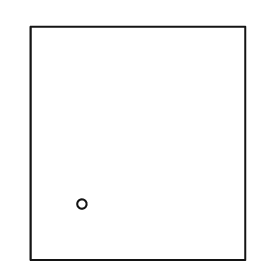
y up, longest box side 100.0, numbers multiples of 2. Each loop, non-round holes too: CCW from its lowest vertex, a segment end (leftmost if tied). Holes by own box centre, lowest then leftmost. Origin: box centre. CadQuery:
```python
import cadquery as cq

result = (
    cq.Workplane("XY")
    .moveTo(-46.0, -50.0)
    .lineTo(46.0, -50.0)
    .lineTo(46.0, 50.0)
    .lineTo(-46.0, 50.0)
    .close()
    .moveTo(-24.0, -26.0)
    .circle(2.0)
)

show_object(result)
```